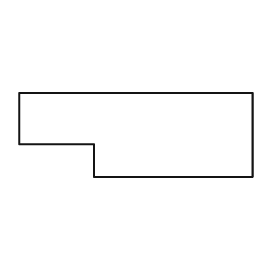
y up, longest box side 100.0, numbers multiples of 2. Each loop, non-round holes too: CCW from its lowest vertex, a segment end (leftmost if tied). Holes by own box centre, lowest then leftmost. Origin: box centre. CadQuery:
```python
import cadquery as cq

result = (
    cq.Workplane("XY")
    .moveTo(-18.0, -18.0)
    .lineTo(50.0, -18.0)
    .lineTo(50.0, 18.0)
    .lineTo(-50.0, 18.0)
    .lineTo(-50.0, -4.0)
    .lineTo(-18.0, -4.0)
    .close()
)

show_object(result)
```